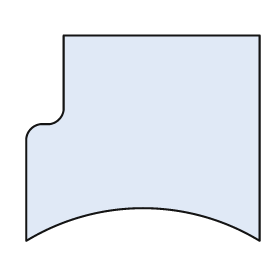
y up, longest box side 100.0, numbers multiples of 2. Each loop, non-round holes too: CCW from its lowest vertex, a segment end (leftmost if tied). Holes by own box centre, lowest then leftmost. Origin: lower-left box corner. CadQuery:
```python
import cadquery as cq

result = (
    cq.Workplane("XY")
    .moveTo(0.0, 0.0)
    .threePointArc((50.0, 14.0), (100.0, 0.0))
    .lineTo(100.0, 88.0)
    .lineTo(16.0, 88.0)
    .lineTo(16.0, 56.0)
    .threePointArc((14.0, 52.0), (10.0, 50.0))
    .lineTo(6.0, 50.0)
    .threePointArc((2.0, 48.0), (0.0, 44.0))
    .close()
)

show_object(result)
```